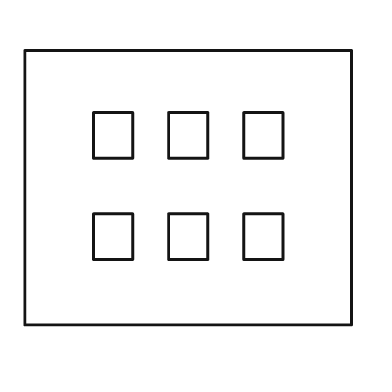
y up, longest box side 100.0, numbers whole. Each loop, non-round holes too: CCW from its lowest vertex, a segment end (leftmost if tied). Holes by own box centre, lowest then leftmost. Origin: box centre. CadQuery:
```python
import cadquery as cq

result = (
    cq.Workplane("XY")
    .moveTo(-50.0, -42.0)
    .lineTo(50.0, -42.0)
    .lineTo(50.0, 42.0)
    .lineTo(-50.0, 42.0)
    .close()
    .moveTo(-29.0, -22.0)
    .lineTo(-17.0, -22.0)
    .lineTo(-17.0, -8.0)
    .lineTo(-29.0, -8.0)
    .close()
    .moveTo(-6.0, -22.0)
    .lineTo(6.0, -22.0)
    .lineTo(6.0, -8.0)
    .lineTo(-6.0, -8.0)
    .close()
    .moveTo(17.0, -22.0)
    .lineTo(29.0, -22.0)
    .lineTo(29.0, -8.0)
    .lineTo(17.0, -8.0)
    .close()
    .moveTo(-29.0, 9.0)
    .lineTo(-17.0, 9.0)
    .lineTo(-17.0, 23.0)
    .lineTo(-29.0, 23.0)
    .close()
    .moveTo(-6.0, 9.0)
    .lineTo(6.0, 9.0)
    .lineTo(6.0, 23.0)
    .lineTo(-6.0, 23.0)
    .close()
    .moveTo(17.0, 9.0)
    .lineTo(29.0, 9.0)
    .lineTo(29.0, 23.0)
    .lineTo(17.0, 23.0)
    .close()
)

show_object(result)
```